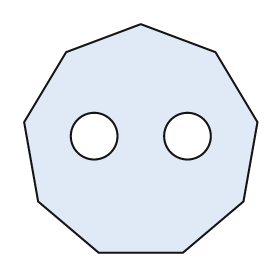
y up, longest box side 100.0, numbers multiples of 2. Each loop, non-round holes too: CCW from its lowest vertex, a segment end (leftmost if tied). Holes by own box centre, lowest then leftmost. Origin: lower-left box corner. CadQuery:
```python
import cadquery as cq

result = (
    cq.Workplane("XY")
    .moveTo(32.0, 0.0)
    .lineTo(68.0, 0.0)
    .lineTo(94.0, 22.0)
    .lineTo(100.0, 56.0)
    .lineTo(82.0, 86.0)
    .lineTo(50.0, 98.0)
    .lineTo(18.0, 86.0)
    .lineTo(0.0, 56.0)
    .lineTo(6.0, 22.0)
    .close()
    .moveTo(30.0, 50.0)
    .circle(10.0)
    .moveTo(70.0, 50.0)
    .circle(10.0)
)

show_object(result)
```